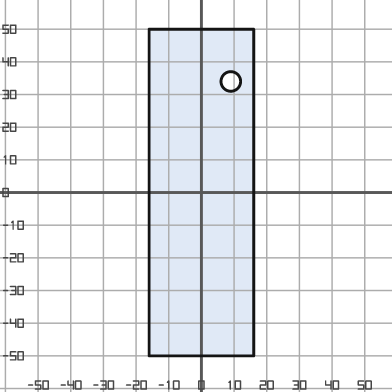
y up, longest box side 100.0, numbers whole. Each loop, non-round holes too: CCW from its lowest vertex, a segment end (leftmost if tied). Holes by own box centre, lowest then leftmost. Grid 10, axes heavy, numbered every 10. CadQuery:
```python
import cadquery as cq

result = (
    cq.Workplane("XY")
    .moveTo(-16.0, -50.0)
    .lineTo(16.0, -50.0)
    .lineTo(16.0, 50.0)
    .lineTo(-16.0, 50.0)
    .close()
    .moveTo(9.0, 34.0)
    .circle(3.0)
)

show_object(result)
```